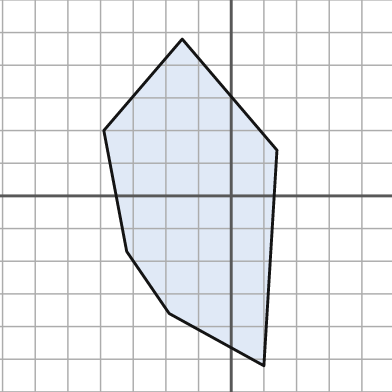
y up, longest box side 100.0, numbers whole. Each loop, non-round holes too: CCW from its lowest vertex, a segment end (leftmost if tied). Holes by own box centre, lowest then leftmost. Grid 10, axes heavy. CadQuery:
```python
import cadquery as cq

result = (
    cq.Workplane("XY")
    .moveTo(10.0, -52.0)
    .lineTo(14.0, 14.0)
    .lineTo(-15.0, 48.0)
    .lineTo(-39.0, 20.0)
    .lineTo(-32.0, -17.0)
    .lineTo(-19.0, -36.0)
    .close()
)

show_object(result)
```